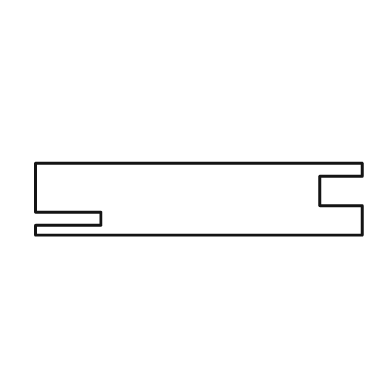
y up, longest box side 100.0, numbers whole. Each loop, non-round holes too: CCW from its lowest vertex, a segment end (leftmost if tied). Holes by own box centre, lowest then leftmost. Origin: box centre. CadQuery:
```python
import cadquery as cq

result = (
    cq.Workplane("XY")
    .moveTo(-50.0, -11.0)
    .lineTo(50.0, -11.0)
    .lineTo(50.0, -2.0)
    .lineTo(37.0, -2.0)
    .lineTo(37.0, 7.0)
    .lineTo(50.0, 7.0)
    .lineTo(50.0, 11.0)
    .lineTo(-50.0, 11.0)
    .lineTo(-50.0, -4.0)
    .lineTo(-30.0, -4.0)
    .lineTo(-30.0, -8.0)
    .lineTo(-50.0, -8.0)
    .close()
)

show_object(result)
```